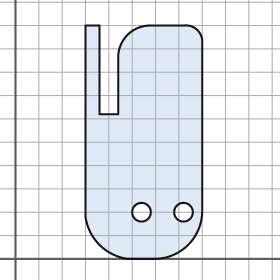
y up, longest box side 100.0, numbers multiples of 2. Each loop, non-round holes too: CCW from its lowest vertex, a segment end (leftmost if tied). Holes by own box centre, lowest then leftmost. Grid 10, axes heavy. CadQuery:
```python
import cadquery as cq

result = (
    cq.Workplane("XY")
    .moveTo(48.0, 0.0)
    .lineTo(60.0, 0.0)
    .threePointArc((74.0, 6.0), (80.0, 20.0))
    .lineTo(80.0, 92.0)
    .threePointArc((78.0, 98.0), (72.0, 100.0))
    .lineTo(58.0, 100.0)
    .threePointArc((48.0, 96.0), (44.0, 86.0))
    .lineTo(44.0, 62.0)
    .lineTo(36.0, 62.0)
    .lineTo(36.0, 100.0)
    .lineTo(30.0, 100.0)
    .lineTo(30.0, 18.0)
    .threePointArc((36.0, 6.0), (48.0, 0.0))
    .close()
    .moveTo(54.0, 20.0)
    .circle(4.0)
    .moveTo(72.0, 20.0)
    .circle(4.0)
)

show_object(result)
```